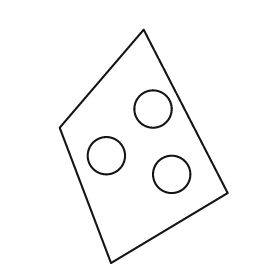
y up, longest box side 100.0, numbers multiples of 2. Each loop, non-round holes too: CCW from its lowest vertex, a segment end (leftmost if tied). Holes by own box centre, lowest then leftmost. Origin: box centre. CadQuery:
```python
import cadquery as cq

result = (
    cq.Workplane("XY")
    .moveTo(-14.0, -50.0)
    .lineTo(36.0, -20.0)
    .lineTo(0.0, 50.0)
    .lineTo(-36.0, 8.0)
    .close()
    .moveTo(12.0, -12.0)
    .circle(8.0)
    .moveTo(-16.0, -4.0)
    .circle(8.0)
    .moveTo(4.0, 16.0)
    .circle(8.0)
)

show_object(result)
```